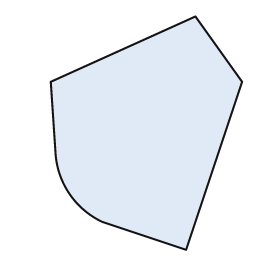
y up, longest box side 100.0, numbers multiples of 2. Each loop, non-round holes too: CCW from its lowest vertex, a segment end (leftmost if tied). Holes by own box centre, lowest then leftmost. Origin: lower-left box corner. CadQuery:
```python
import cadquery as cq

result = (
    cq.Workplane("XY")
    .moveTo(58.0, 0.0)
    .lineTo(82.0, 72.0)
    .lineTo(62.0, 100.0)
    .lineTo(0.0, 72.0)
    .lineTo(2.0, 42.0)
    .threePointArc((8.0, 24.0), (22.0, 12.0))
    .close()
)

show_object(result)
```